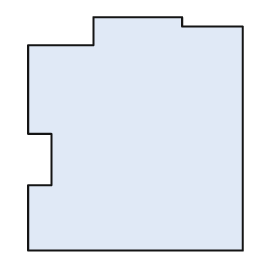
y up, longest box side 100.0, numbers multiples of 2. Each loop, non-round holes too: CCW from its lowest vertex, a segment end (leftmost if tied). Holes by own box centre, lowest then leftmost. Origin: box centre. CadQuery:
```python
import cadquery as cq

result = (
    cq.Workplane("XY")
    .moveTo(-46.0, -50.0)
    .lineTo(46.0, -50.0)
    .lineTo(46.0, 46.0)
    .lineTo(20.0, 46.0)
    .lineTo(20.0, 50.0)
    .lineTo(-18.0, 50.0)
    .lineTo(-18.0, 38.0)
    .lineTo(-46.0, 38.0)
    .lineTo(-46.0, 0.0)
    .lineTo(-36.0, 0.0)
    .lineTo(-36.0, -22.0)
    .lineTo(-46.0, -22.0)
    .close()
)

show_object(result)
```